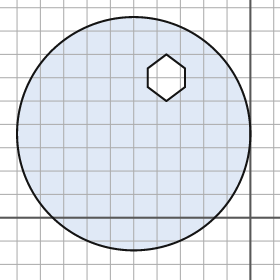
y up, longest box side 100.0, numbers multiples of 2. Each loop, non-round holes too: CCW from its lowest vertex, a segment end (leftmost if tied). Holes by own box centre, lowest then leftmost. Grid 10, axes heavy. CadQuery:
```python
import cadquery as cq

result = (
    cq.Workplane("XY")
    .moveTo(-50.0, 36.0)
    .circle(50.0)
    .moveTo(-36.0, 50.0)
    .lineTo(-28.0, 56.0)
    .lineTo(-28.0, 64.0)
    .lineTo(-36.0, 70.0)
    .lineTo(-44.0, 64.0)
    .lineTo(-44.0, 56.0)
    .close()
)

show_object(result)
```